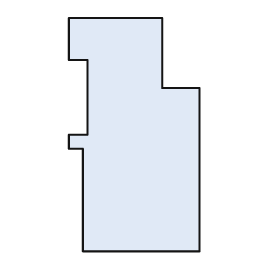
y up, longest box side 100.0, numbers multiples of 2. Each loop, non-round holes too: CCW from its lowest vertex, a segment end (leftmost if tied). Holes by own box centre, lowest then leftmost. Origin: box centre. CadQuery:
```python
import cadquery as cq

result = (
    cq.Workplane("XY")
    .moveTo(-22.0, -50.0)
    .lineTo(28.0, -50.0)
    .lineTo(28.0, 20.0)
    .lineTo(12.0, 20.0)
    .lineTo(12.0, 50.0)
    .lineTo(-28.0, 50.0)
    .lineTo(-28.0, 32.0)
    .lineTo(-20.0, 32.0)
    .lineTo(-20.0, 0.0)
    .lineTo(-28.0, 0.0)
    .lineTo(-28.0, -6.0)
    .lineTo(-22.0, -6.0)
    .close()
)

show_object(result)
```